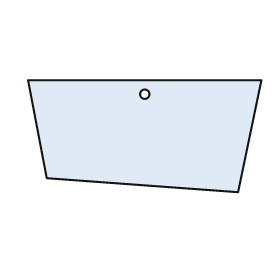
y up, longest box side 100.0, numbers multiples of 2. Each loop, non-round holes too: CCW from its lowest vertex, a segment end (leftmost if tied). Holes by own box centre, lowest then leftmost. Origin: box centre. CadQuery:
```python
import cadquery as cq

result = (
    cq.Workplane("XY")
    .moveTo(40.0, -24.0)
    .lineTo(50.0, 24.0)
    .lineTo(-50.0, 24.0)
    .lineTo(-42.0, -18.0)
    .close()
    .moveTo(0.0, 18.0)
    .circle(2.0)
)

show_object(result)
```